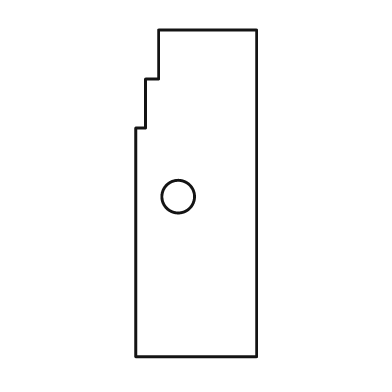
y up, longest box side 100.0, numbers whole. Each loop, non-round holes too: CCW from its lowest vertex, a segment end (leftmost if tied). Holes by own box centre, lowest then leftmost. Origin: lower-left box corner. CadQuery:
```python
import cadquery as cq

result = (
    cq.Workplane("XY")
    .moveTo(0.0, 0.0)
    .lineTo(37.0, 0.0)
    .lineTo(37.0, 100.0)
    .lineTo(7.0, 100.0)
    .lineTo(7.0, 85.0)
    .lineTo(3.0, 85.0)
    .lineTo(3.0, 70.0)
    .lineTo(0.0, 70.0)
    .close()
    .moveTo(13.0, 49.0)
    .circle(5.0)
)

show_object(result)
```